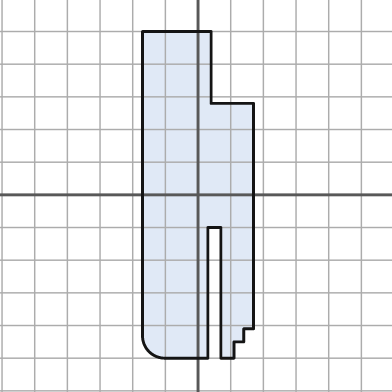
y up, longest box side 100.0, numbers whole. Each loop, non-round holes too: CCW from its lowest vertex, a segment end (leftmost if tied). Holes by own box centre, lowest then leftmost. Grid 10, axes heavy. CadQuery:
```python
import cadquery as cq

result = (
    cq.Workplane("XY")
    .moveTo(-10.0, -50.0)
    .lineTo(3.0, -50.0)
    .lineTo(3.0, -10.0)
    .lineTo(7.0, -10.0)
    .lineTo(7.0, -50.0)
    .lineTo(11.0, -50.0)
    .lineTo(11.0, -45.0)
    .lineTo(14.0, -45.0)
    .lineTo(14.0, -41.0)
    .lineTo(17.0, -41.0)
    .lineTo(17.0, 28.0)
    .lineTo(4.0, 28.0)
    .lineTo(4.0, 50.0)
    .lineTo(-17.0, 50.0)
    .lineTo(-17.0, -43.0)
    .threePointArc((-15.0, -48.0), (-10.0, -50.0))
    .close()
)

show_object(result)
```